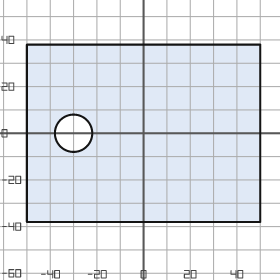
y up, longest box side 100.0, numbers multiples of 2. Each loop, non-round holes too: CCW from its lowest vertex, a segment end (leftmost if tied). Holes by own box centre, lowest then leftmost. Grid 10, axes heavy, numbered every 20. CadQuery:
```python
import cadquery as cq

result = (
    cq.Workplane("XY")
    .moveTo(-50.0, -38.0)
    .lineTo(50.0, -38.0)
    .lineTo(50.0, 38.0)
    .lineTo(-50.0, 38.0)
    .close()
    .moveTo(-30.0, 0.0)
    .circle(8.0)
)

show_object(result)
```